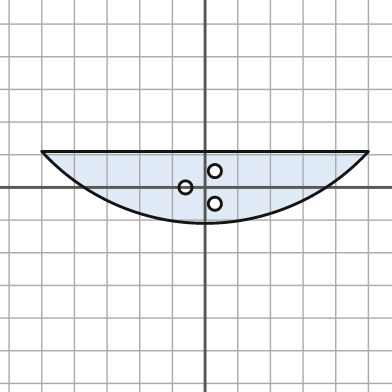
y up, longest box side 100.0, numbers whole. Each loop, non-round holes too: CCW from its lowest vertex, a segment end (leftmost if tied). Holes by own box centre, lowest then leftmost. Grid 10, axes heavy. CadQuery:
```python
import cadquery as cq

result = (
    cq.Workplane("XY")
    .moveTo(-50.0, 11.0)
    .threePointArc((0.0, -11.0), (50.0, 11.0))
    .close()
    .moveTo(3.0, -5.0)
    .circle(2.0)
    .moveTo(-6.0, 0.0)
    .circle(2.0)
    .moveTo(3.0, 5.0)
    .circle(2.0)
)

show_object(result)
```